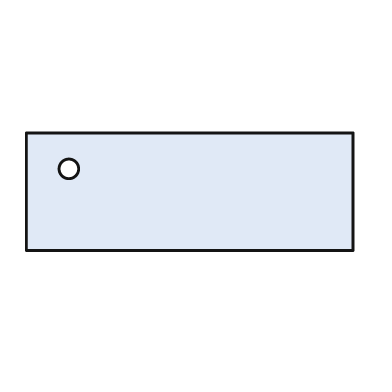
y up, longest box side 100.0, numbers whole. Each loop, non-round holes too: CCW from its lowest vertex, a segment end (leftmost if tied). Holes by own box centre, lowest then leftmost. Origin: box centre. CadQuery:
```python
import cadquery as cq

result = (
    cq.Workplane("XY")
    .moveTo(-50.0, -18.0)
    .lineTo(50.0, -18.0)
    .lineTo(50.0, 18.0)
    .lineTo(-50.0, 18.0)
    .close()
    .moveTo(-37.0, 7.0)
    .circle(3.0)
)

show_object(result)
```